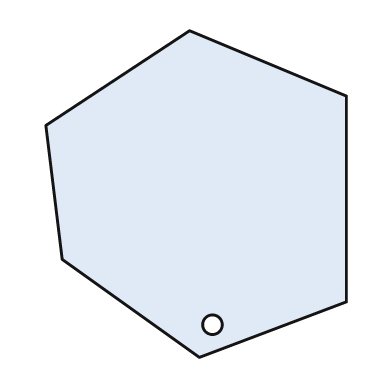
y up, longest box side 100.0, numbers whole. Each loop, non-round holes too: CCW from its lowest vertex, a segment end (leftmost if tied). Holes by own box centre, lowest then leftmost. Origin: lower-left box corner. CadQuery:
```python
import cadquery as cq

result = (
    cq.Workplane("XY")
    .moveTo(47.0, 0.0)
    .lineTo(92.0, 17.0)
    .lineTo(92.0, 80.0)
    .lineTo(44.0, 100.0)
    .lineTo(0.0, 71.0)
    .lineTo(5.0, 30.0)
    .close()
    .moveTo(51.0, 10.0)
    .circle(3.0)
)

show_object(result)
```